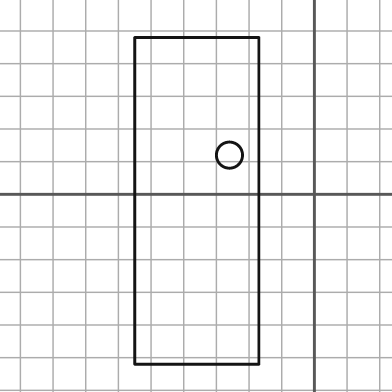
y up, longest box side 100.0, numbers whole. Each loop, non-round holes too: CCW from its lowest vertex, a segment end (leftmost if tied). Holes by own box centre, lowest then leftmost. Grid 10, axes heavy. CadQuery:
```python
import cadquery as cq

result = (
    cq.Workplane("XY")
    .moveTo(-55.0, -52.0)
    .lineTo(-17.0, -52.0)
    .lineTo(-17.0, 48.0)
    .lineTo(-55.0, 48.0)
    .close()
    .moveTo(-26.0, 12.0)
    .circle(4.0)
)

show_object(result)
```